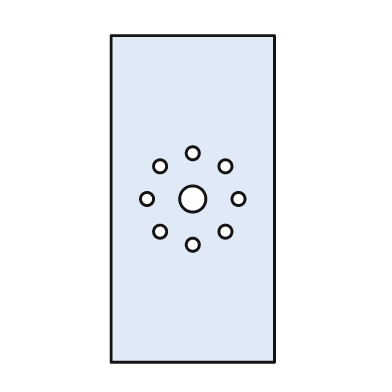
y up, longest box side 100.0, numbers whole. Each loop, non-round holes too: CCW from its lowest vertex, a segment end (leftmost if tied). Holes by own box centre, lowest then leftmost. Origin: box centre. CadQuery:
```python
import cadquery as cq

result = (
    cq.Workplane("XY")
    .moveTo(-25.0, -50.0)
    .lineTo(25.0, -50.0)
    .lineTo(25.0, 50.0)
    .lineTo(-25.0, 50.0)
    .close()
    .moveTo(0.0, -14.0)
    .circle(2.0)
    .moveTo(-10.0, -10.0)
    .circle(2.0)
    .moveTo(10.0, -10.0)
    .circle(2.0)
    .moveTo(-14.0, 0.0)
    .circle(2.0)
    .moveTo(0.0, 0.0)
    .circle(4.0)
    .moveTo(14.0, 0.0)
    .circle(2.0)
    .moveTo(-10.0, 10.0)
    .circle(2.0)
    .moveTo(10.0, 10.0)
    .circle(2.0)
    .moveTo(0.0, 14.0)
    .circle(2.0)
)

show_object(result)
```